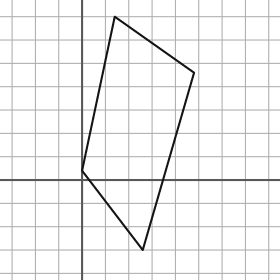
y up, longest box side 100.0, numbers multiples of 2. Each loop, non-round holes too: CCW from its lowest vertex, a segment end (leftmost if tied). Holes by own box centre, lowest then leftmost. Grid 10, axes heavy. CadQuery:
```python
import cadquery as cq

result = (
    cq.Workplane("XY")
    .moveTo(26.0, -30.0)
    .lineTo(48.0, 46.0)
    .lineTo(14.0, 70.0)
    .lineTo(0.0, 4.0)
    .close()
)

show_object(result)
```